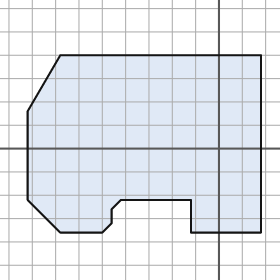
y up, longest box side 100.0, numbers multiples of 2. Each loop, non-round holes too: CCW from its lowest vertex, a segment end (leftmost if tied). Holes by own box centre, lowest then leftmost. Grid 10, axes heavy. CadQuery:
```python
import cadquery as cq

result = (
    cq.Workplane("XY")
    .moveTo(-68.0, -36.0)
    .lineTo(-50.0, -36.0)
    .lineTo(-46.0, -32.0)
    .lineTo(-46.0, -26.0)
    .lineTo(-42.0, -22.0)
    .lineTo(-12.0, -22.0)
    .lineTo(-12.0, -36.0)
    .lineTo(18.0, -36.0)
    .lineTo(18.0, 40.0)
    .lineTo(-68.0, 40.0)
    .lineTo(-82.0, 16.0)
    .lineTo(-82.0, -22.0)
    .close()
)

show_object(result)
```